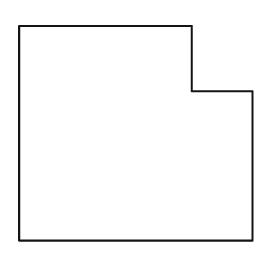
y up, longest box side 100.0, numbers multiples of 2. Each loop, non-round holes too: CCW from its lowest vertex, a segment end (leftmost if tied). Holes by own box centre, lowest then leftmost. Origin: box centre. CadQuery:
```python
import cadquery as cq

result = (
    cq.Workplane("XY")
    .moveTo(-50.0, -46.0)
    .lineTo(50.0, -46.0)
    .lineTo(50.0, 18.0)
    .lineTo(24.0, 18.0)
    .lineTo(24.0, 46.0)
    .lineTo(-50.0, 46.0)
    .close()
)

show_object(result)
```